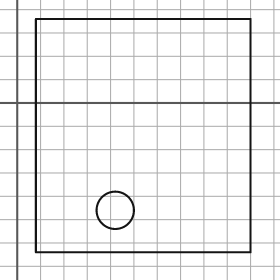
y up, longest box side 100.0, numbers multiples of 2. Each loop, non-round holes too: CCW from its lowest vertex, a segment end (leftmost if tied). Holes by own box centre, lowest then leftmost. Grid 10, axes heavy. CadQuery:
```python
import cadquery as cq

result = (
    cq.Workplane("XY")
    .moveTo(8.0, -64.0)
    .lineTo(100.0, -64.0)
    .lineTo(100.0, 36.0)
    .lineTo(8.0, 36.0)
    .close()
    .moveTo(42.0, -46.0)
    .circle(8.0)
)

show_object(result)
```